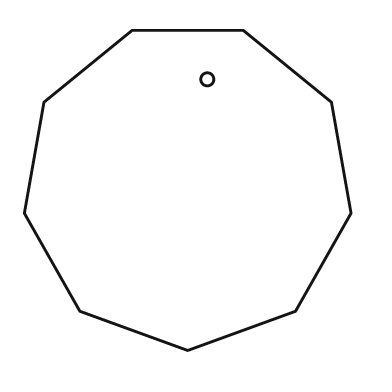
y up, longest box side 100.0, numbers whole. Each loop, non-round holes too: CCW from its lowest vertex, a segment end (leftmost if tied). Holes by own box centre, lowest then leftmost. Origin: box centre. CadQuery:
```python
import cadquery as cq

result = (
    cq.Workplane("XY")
    .moveTo(0.0, -49.0)
    .lineTo(33.0, -37.0)
    .lineTo(50.0, -7.0)
    .lineTo(44.0, 27.0)
    .lineTo(17.0, 49.0)
    .lineTo(-17.0, 49.0)
    .lineTo(-44.0, 27.0)
    .lineTo(-50.0, -7.0)
    .lineTo(-33.0, -37.0)
    .close()
    .moveTo(6.0, 34.0)
    .circle(2.0)
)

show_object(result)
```